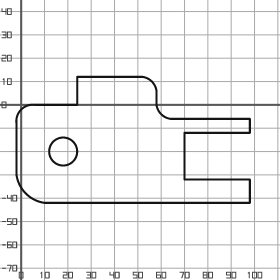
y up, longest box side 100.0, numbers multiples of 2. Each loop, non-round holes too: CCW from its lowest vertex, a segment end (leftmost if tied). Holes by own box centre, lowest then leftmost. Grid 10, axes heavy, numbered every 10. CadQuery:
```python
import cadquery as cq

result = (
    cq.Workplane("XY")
    .moveTo(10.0, -42.0)
    .lineTo(98.0, -42.0)
    .lineTo(98.0, -32.0)
    .lineTo(70.0, -32.0)
    .lineTo(70.0, -12.0)
    .lineTo(98.0, -12.0)
    .lineTo(98.0, -6.0)
    .lineTo(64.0, -6.0)
    .threePointArc((60.0, -4.0), (58.0, 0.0))
    .lineTo(58.0, 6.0)
    .threePointArc((56.0, 10.0), (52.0, 12.0))
    .lineTo(24.0, 12.0)
    .lineTo(24.0, 0.0)
    .lineTo(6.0, 0.0)
    .threePointArc((0.0, -2.0), (-2.0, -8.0))
    .lineTo(-2.0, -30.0)
    .threePointArc((2.0, -38.0), (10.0, -42.0))
    .close()
    .moveTo(18.0, -20.0)
    .circle(6.0)
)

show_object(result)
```